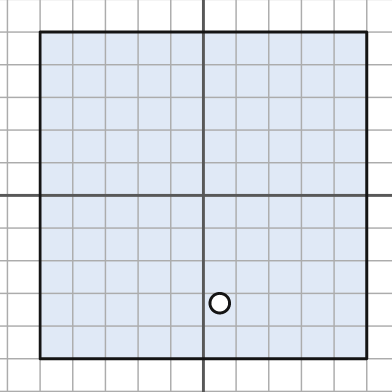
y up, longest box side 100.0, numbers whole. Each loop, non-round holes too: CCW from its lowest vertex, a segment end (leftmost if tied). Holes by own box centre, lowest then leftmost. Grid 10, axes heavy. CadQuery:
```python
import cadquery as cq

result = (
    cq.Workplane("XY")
    .moveTo(-50.0, -50.0)
    .lineTo(50.0, -50.0)
    .lineTo(50.0, 50.0)
    .lineTo(-50.0, 50.0)
    .close()
    .moveTo(5.0, -33.0)
    .circle(3.0)
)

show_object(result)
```